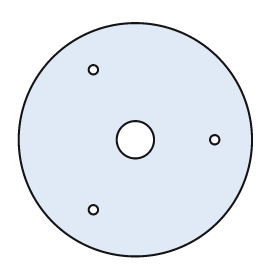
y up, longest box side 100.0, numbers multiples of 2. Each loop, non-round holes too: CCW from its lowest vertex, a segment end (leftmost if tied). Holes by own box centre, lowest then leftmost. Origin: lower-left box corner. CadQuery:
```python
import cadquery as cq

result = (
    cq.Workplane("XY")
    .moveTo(50.0, 50.0)
    .circle(50.0)
    .moveTo(32.0, 20.0)
    .circle(2.0)
    .moveTo(50.0, 50.0)
    .circle(8.0)
    .moveTo(84.0, 50.0)
    .circle(2.0)
    .moveTo(32.0, 80.0)
    .circle(2.0)
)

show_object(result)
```